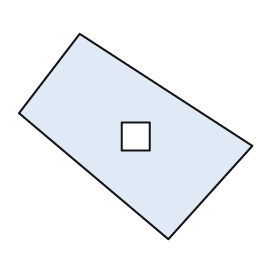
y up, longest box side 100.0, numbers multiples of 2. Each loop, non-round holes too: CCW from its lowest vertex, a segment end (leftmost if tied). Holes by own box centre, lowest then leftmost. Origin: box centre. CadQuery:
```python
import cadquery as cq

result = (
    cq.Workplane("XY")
    .moveTo(14.0, -44.0)
    .lineTo(50.0, -4.0)
    .lineTo(-24.0, 44.0)
    .lineTo(-50.0, 10.0)
    .close()
    .moveTo(-6.0, -6.0)
    .lineTo(6.0, -6.0)
    .lineTo(6.0, 6.0)
    .lineTo(-6.0, 6.0)
    .close()
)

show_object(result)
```